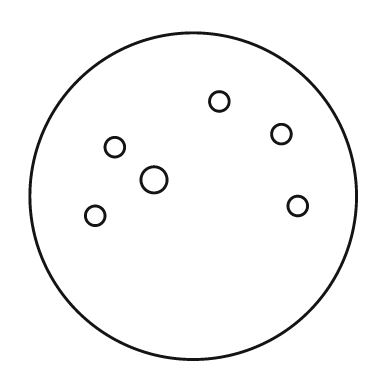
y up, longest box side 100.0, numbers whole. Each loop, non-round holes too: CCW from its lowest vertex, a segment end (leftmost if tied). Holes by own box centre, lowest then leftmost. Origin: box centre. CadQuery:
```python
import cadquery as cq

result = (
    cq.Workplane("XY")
    .moveTo(0.0, 0.0)
    .circle(50.0)
    .moveTo(-30.0, -6.0)
    .circle(3.0)
    .moveTo(32.0, -3.0)
    .circle(3.0)
    .moveTo(-12.0, 5.0)
    .circle(4.0)
    .moveTo(-24.0, 15.0)
    .circle(3.0)
    .moveTo(27.0, 19.0)
    .circle(3.0)
    .moveTo(8.0, 29.0)
    .circle(3.0)
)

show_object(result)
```